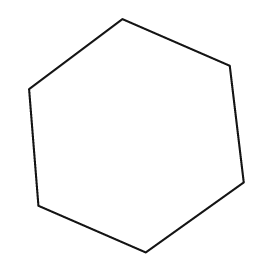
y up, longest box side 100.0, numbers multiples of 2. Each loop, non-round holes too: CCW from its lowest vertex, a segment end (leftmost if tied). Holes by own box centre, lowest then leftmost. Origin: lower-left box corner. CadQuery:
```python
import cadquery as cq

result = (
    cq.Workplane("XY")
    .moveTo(50.0, 0.0)
    .lineTo(92.0, 30.0)
    .lineTo(86.0, 80.0)
    .lineTo(40.0, 100.0)
    .lineTo(0.0, 70.0)
    .lineTo(4.0, 20.0)
    .close()
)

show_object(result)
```